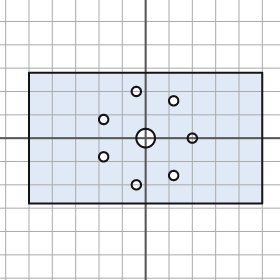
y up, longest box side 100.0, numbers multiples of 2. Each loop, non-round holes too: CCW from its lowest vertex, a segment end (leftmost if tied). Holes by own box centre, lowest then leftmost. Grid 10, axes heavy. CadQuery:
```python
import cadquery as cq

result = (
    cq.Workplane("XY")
    .moveTo(-50.0, -28.0)
    .lineTo(50.0, -28.0)
    .lineTo(50.0, 28.0)
    .lineTo(-50.0, 28.0)
    .close()
    .moveTo(-4.0, -20.0)
    .circle(2.0)
    .moveTo(12.0, -16.0)
    .circle(2.0)
    .moveTo(-18.0, -8.0)
    .circle(2.0)
    .moveTo(0.0, 0.0)
    .circle(4.0)
    .moveTo(20.0, 0.0)
    .circle(2.0)
    .moveTo(-18.0, 8.0)
    .circle(2.0)
    .moveTo(12.0, 16.0)
    .circle(2.0)
    .moveTo(-4.0, 20.0)
    .circle(2.0)
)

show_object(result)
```